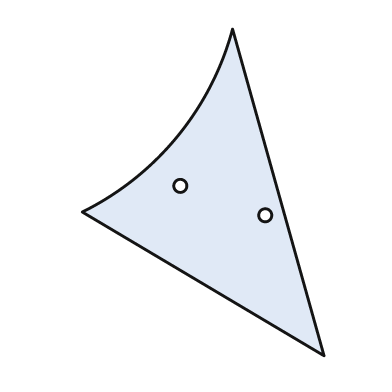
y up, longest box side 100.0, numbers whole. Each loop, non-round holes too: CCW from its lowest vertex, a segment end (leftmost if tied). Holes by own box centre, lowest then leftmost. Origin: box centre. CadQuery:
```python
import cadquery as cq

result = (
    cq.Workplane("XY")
    .moveTo(37.0, -50.0)
    .lineTo(9.0, 50.0)
    .threePointArc((-8.0, 17.0), (-37.0, -6.0))
    .close()
    .moveTo(19.0, -7.0)
    .circle(2.0)
    .moveTo(-7.0, 2.0)
    .circle(2.0)
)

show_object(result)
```